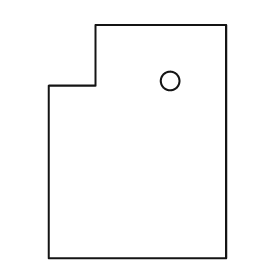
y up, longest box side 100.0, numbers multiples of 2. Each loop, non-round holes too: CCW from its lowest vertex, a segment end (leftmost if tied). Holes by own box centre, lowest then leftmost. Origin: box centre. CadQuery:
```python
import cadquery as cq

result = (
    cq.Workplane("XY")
    .moveTo(-38.0, -50.0)
    .lineTo(38.0, -50.0)
    .lineTo(38.0, 50.0)
    .lineTo(-18.0, 50.0)
    .lineTo(-18.0, 24.0)
    .lineTo(-38.0, 24.0)
    .close()
    .moveTo(14.0, 26.0)
    .circle(4.0)
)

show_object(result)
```